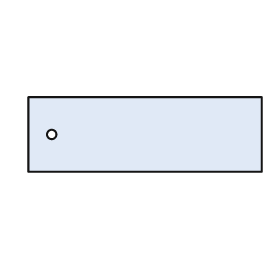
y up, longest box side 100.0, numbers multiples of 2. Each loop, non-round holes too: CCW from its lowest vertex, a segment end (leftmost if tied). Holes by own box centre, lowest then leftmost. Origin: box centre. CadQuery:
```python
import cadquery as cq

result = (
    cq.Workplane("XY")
    .moveTo(-50.0, -16.0)
    .lineTo(50.0, -16.0)
    .lineTo(50.0, 16.0)
    .lineTo(-50.0, 16.0)
    .close()
    .moveTo(-40.0, 0.0)
    .circle(2.0)
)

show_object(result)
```